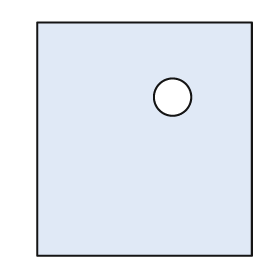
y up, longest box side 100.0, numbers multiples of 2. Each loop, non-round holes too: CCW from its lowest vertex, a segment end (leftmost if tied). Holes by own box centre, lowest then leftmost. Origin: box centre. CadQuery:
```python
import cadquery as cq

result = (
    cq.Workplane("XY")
    .moveTo(-46.0, -50.0)
    .lineTo(46.0, -50.0)
    .lineTo(46.0, 50.0)
    .lineTo(-46.0, 50.0)
    .close()
    .moveTo(12.0, 18.0)
    .circle(8.0)
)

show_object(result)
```